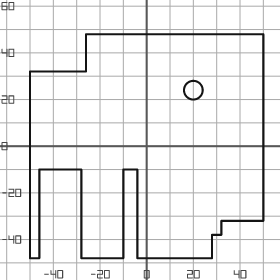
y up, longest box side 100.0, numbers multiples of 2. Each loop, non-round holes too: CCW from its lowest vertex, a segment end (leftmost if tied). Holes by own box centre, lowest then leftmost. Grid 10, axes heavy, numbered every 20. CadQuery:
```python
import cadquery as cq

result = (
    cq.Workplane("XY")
    .moveTo(-50.0, -48.0)
    .lineTo(-46.0, -48.0)
    .lineTo(-46.0, -10.0)
    .lineTo(-28.0, -10.0)
    .lineTo(-28.0, -48.0)
    .lineTo(-10.0, -48.0)
    .lineTo(-10.0, -10.0)
    .lineTo(-4.0, -10.0)
    .lineTo(-4.0, -48.0)
    .lineTo(28.0, -48.0)
    .lineTo(28.0, -38.0)
    .lineTo(32.0, -38.0)
    .lineTo(32.0, -32.0)
    .lineTo(50.0, -32.0)
    .lineTo(50.0, 48.0)
    .lineTo(-26.0, 48.0)
    .lineTo(-26.0, 32.0)
    .lineTo(-50.0, 32.0)
    .close()
    .moveTo(20.0, 24.0)
    .circle(4.0)
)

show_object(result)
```